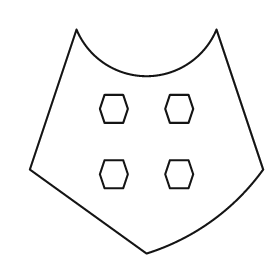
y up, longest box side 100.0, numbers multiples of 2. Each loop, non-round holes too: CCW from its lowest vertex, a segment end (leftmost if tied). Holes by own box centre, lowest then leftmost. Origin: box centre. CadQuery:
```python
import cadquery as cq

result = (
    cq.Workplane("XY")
    .moveTo(0.0, -48.0)
    .threePointArc((28.0, -34.0), (50.0, -12.0))
    .lineTo(30.0, 48.0)
    .threePointArc((0.0, 28.0), (-30.0, 48.0))
    .lineTo(-50.0, -12.0)
    .close()
    .moveTo(-18.0, -20.0)
    .lineTo(-10.0, -20.0)
    .lineTo(-8.0, -14.0)
    .lineTo(-10.0, -8.0)
    .lineTo(-18.0, -8.0)
    .lineTo(-20.0, -14.0)
    .close()
    .moveTo(10.0, -20.0)
    .lineTo(18.0, -20.0)
    .lineTo(20.0, -14.0)
    .lineTo(18.0, -8.0)
    .lineTo(10.0, -8.0)
    .lineTo(8.0, -14.0)
    .close()
    .moveTo(-18.0, 8.0)
    .lineTo(-10.0, 8.0)
    .lineTo(-8.0, 14.0)
    .lineTo(-10.0, 20.0)
    .lineTo(-18.0, 20.0)
    .lineTo(-20.0, 14.0)
    .close()
    .moveTo(10.0, 8.0)
    .lineTo(18.0, 8.0)
    .lineTo(20.0, 14.0)
    .lineTo(18.0, 20.0)
    .lineTo(10.0, 20.0)
    .lineTo(8.0, 14.0)
    .close()
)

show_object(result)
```